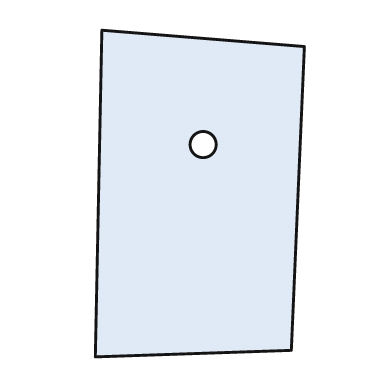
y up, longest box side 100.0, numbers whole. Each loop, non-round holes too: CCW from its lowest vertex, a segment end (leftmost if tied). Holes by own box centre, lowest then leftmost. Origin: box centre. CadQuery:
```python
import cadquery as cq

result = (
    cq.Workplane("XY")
    .moveTo(-32.0, -50.0)
    .lineTo(28.0, -48.0)
    .lineTo(32.0, 45.0)
    .lineTo(-30.0, 50.0)
    .close()
    .moveTo(1.0, 15.0)
    .circle(4.0)
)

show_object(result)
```